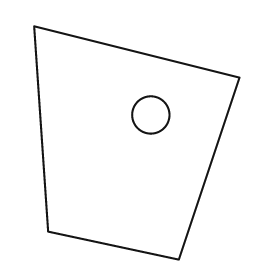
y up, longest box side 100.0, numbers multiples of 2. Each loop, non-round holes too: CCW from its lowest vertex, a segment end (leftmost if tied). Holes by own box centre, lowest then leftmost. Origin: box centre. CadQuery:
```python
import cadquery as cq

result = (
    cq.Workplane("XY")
    .moveTo(18.0, -50.0)
    .lineTo(44.0, 28.0)
    .lineTo(-44.0, 50.0)
    .lineTo(-38.0, -38.0)
    .close()
    .moveTo(6.0, 12.0)
    .circle(8.0)
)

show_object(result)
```